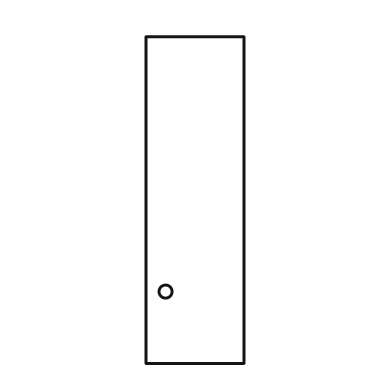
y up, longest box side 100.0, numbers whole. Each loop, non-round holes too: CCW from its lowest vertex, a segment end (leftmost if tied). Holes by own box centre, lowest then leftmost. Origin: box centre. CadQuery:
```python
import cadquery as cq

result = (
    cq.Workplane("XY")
    .moveTo(-15.0, -50.0)
    .lineTo(15.0, -50.0)
    .lineTo(15.0, 50.0)
    .lineTo(-15.0, 50.0)
    .close()
    .moveTo(-9.0, -28.0)
    .circle(2.0)
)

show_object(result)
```